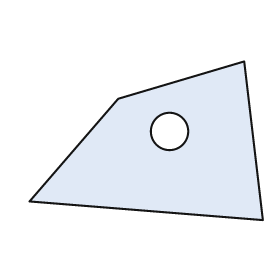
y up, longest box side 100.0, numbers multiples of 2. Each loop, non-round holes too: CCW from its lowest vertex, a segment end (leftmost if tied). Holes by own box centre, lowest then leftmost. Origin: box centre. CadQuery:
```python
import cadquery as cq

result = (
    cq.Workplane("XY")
    .moveTo(50.0, -34.0)
    .lineTo(42.0, 34.0)
    .lineTo(-12.0, 18.0)
    .lineTo(-50.0, -26.0)
    .close()
    .moveTo(10.0, 4.0)
    .circle(8.0)
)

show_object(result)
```